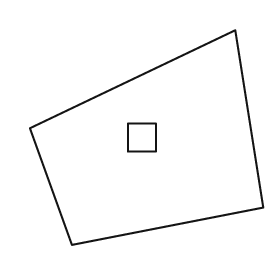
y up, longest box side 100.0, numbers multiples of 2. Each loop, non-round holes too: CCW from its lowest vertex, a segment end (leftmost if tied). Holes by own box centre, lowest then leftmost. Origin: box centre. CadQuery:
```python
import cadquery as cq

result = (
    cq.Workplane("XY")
    .moveTo(-32.0, -46.0)
    .lineTo(50.0, -30.0)
    .lineTo(38.0, 46.0)
    .lineTo(-50.0, 4.0)
    .close()
    .moveTo(-8.0, -6.0)
    .lineTo(4.0, -6.0)
    .lineTo(4.0, 6.0)
    .lineTo(-8.0, 6.0)
    .close()
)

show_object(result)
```